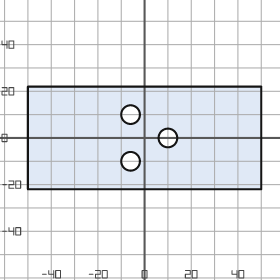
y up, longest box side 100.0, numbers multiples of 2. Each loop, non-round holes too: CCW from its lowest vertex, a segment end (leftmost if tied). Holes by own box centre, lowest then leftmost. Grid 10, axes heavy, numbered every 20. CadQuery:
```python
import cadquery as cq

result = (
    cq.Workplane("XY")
    .moveTo(-50.0, -22.0)
    .lineTo(50.0, -22.0)
    .lineTo(50.0, 22.0)
    .lineTo(-50.0, 22.0)
    .close()
    .moveTo(-6.0, -10.0)
    .circle(4.0)
    .moveTo(10.0, 0.0)
    .circle(4.0)
    .moveTo(-6.0, 10.0)
    .circle(4.0)
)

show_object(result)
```